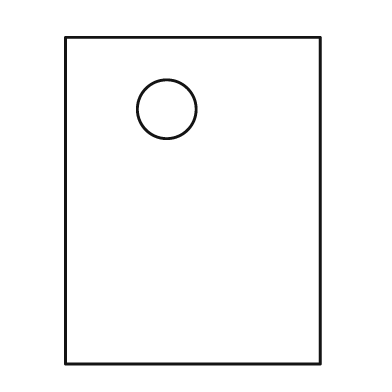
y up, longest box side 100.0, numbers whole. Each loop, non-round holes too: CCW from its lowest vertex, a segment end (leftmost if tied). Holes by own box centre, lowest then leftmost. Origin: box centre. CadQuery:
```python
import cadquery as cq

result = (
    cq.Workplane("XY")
    .moveTo(-39.0, -50.0)
    .lineTo(39.0, -50.0)
    .lineTo(39.0, 50.0)
    .lineTo(-39.0, 50.0)
    .close()
    .moveTo(-8.0, 28.0)
    .circle(9.0)
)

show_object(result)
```